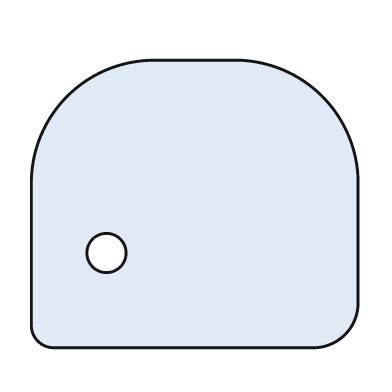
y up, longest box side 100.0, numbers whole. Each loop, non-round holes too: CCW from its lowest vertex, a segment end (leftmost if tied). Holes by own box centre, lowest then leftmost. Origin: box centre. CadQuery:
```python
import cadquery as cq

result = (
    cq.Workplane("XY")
    .moveTo(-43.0, -44.0)
    .lineTo(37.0, -44.0)
    .threePointArc((46.0, -40.0), (50.0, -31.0))
    .lineTo(50.0, 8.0)
    .threePointArc((39.0, 33.0), (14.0, 44.0))
    .lineTo(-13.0, 44.0)
    .threePointArc((-39.0, 33.0), (-50.0, 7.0))
    .lineTo(-50.0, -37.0)
    .threePointArc((-48.0, -42.0), (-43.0, -44.0))
    .close()
    .moveTo(-27.0, -15.0)
    .circle(6.0)
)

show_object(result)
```